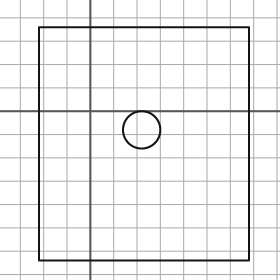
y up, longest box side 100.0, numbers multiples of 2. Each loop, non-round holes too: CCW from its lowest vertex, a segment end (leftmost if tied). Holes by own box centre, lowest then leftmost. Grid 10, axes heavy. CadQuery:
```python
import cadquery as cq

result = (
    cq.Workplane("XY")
    .moveTo(-22.0, -64.0)
    .lineTo(68.0, -64.0)
    .lineTo(68.0, 36.0)
    .lineTo(-22.0, 36.0)
    .close()
    .moveTo(22.0, -8.0)
    .circle(8.0)
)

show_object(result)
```